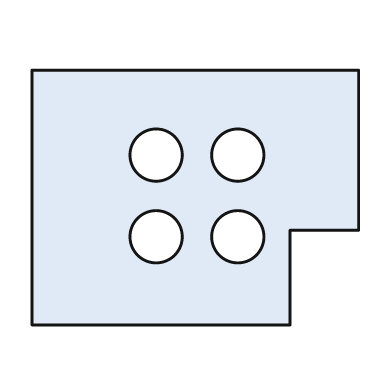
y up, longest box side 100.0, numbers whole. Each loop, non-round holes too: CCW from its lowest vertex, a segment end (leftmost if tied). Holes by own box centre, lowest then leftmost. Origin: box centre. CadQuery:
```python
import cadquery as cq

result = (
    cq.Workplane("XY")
    .moveTo(-50.0, -39.0)
    .lineTo(29.0, -39.0)
    .lineTo(29.0, -10.0)
    .lineTo(50.0, -10.0)
    .lineTo(50.0, 39.0)
    .lineTo(-50.0, 39.0)
    .close()
    .moveTo(-12.0, -12.0)
    .circle(8.0)
    .moveTo(13.0, -12.0)
    .circle(8.0)
    .moveTo(-12.0, 13.0)
    .circle(8.0)
    .moveTo(13.0, 13.0)
    .circle(8.0)
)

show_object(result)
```